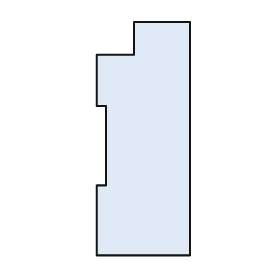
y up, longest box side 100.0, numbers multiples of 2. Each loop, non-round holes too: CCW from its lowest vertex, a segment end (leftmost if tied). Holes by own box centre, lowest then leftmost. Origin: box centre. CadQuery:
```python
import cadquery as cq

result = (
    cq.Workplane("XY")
    .moveTo(-20.0, -50.0)
    .lineTo(20.0, -50.0)
    .lineTo(20.0, 50.0)
    .lineTo(-4.0, 50.0)
    .lineTo(-4.0, 36.0)
    .lineTo(-20.0, 36.0)
    .lineTo(-20.0, 14.0)
    .lineTo(-16.0, 14.0)
    .lineTo(-16.0, -20.0)
    .lineTo(-20.0, -20.0)
    .close()
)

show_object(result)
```